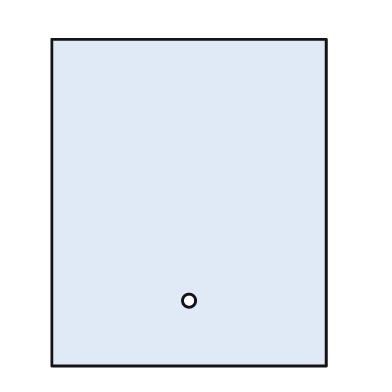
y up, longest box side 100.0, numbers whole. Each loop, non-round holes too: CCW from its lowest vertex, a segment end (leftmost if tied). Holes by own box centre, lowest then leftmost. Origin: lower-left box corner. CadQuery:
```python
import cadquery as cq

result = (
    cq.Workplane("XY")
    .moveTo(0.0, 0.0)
    .lineTo(84.0, 0.0)
    .lineTo(84.0, 100.0)
    .lineTo(0.0, 100.0)
    .close()
    .moveTo(42.0, 20.0)
    .circle(2.0)
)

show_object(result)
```